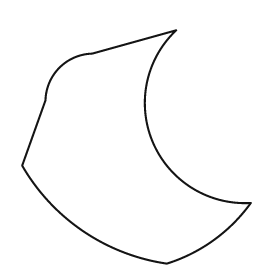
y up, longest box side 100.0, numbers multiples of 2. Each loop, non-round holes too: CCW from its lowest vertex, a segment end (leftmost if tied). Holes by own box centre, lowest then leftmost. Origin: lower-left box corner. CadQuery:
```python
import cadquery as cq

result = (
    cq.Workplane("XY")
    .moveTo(62.0, 0.0)
    .threePointArc((82.0, 10.0), (98.0, 26.0))
    .threePointArc((56.0, 52.0), (66.0, 100.0))
    .lineTo(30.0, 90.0)
    .threePointArc((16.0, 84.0), (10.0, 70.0))
    .lineTo(0.0, 42.0)
    .threePointArc((26.0, 14.0), (62.0, 0.0))
    .close()
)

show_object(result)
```